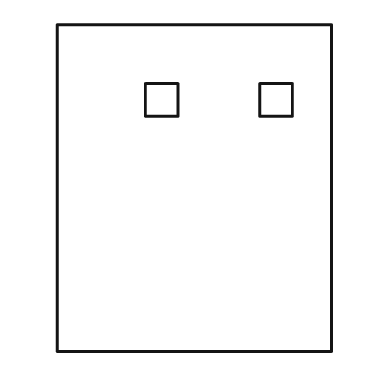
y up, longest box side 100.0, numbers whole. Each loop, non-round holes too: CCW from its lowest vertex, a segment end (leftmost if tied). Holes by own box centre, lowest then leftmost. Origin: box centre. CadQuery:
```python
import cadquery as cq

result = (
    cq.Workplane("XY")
    .moveTo(-42.0, -50.0)
    .lineTo(42.0, -50.0)
    .lineTo(42.0, 50.0)
    .lineTo(-42.0, 50.0)
    .close()
    .moveTo(-15.0, 22.0)
    .lineTo(-5.0, 22.0)
    .lineTo(-5.0, 32.0)
    .lineTo(-15.0, 32.0)
    .close()
    .moveTo(20.0, 22.0)
    .lineTo(30.0, 22.0)
    .lineTo(30.0, 32.0)
    .lineTo(20.0, 32.0)
    .close()
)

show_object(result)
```